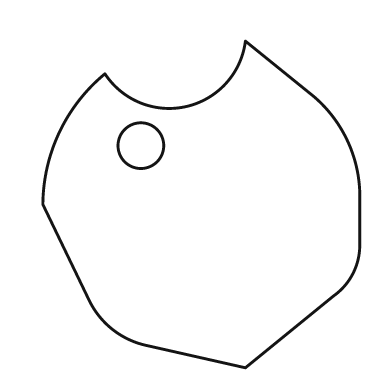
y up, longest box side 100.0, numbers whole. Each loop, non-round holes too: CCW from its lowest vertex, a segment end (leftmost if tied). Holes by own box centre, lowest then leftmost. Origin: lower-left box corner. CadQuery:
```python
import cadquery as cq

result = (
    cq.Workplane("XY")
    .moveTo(62.0, 0.0)
    .lineTo(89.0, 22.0)
    .threePointArc((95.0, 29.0), (97.0, 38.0))
    .lineTo(97.0, 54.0)
    .threePointArc((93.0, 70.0), (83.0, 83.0))
    .lineTo(62.0, 100.0)
    .threePointArc((44.0, 80.0), (19.0, 90.0))
    .threePointArc((5.0, 72.0), (0.0, 50.0))
    .lineTo(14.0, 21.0)
    .threePointArc((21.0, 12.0), (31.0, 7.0))
    .close()
    .moveTo(30.0, 68.0)
    .circle(7.0)
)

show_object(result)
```